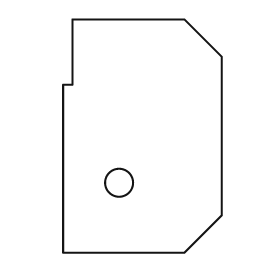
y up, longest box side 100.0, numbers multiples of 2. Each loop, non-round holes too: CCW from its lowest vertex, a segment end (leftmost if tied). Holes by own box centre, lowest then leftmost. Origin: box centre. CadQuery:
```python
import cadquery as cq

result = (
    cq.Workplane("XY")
    .moveTo(-34.0, -50.0)
    .lineTo(18.0, -50.0)
    .lineTo(34.0, -34.0)
    .lineTo(34.0, 34.0)
    .lineTo(18.0, 50.0)
    .lineTo(-30.0, 50.0)
    .lineTo(-30.0, 22.0)
    .lineTo(-34.0, 22.0)
    .close()
    .moveTo(-10.0, -20.0)
    .circle(6.0)
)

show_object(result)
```